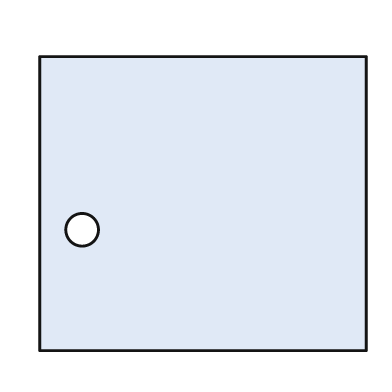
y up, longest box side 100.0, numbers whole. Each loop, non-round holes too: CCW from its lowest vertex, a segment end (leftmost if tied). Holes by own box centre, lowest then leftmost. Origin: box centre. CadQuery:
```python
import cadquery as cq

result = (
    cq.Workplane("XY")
    .moveTo(-50.0, -45.0)
    .lineTo(50.0, -45.0)
    .lineTo(50.0, 45.0)
    .lineTo(-50.0, 45.0)
    .close()
    .moveTo(-37.0, -8.0)
    .circle(5.0)
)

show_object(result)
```